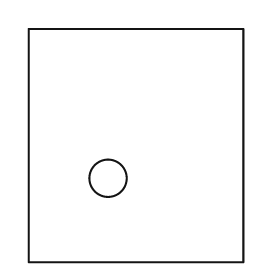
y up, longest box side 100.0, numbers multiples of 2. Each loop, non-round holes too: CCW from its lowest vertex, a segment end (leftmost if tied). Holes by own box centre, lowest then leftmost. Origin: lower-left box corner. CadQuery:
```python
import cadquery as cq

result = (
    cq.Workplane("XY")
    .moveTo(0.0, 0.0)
    .lineTo(92.0, 0.0)
    .lineTo(92.0, 100.0)
    .lineTo(0.0, 100.0)
    .close()
    .moveTo(34.0, 36.0)
    .circle(8.0)
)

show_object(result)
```